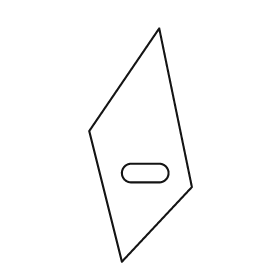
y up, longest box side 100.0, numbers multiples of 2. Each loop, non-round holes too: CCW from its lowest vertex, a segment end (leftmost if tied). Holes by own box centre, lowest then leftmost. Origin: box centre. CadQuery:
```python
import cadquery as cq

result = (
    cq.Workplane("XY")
    .moveTo(-8.0, -50.0)
    .lineTo(22.0, -18.0)
    .lineTo(8.0, 50.0)
    .lineTo(-22.0, 6.0)
    .close()
    .moveTo(-4.0, -16.0)
    .lineTo(8.0, -16.0)
    .threePointArc((12.0, -12.0), (8.0, -8.0))
    .lineTo(-4.0, -8.0)
    .threePointArc((-8.0, -12.0), (-4.0, -16.0))
    .close()
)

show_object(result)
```